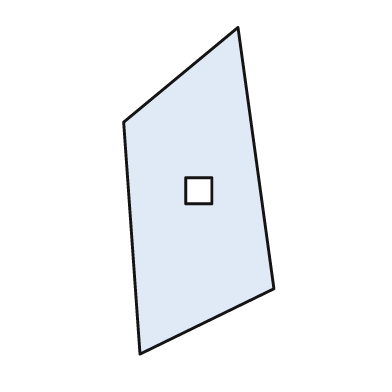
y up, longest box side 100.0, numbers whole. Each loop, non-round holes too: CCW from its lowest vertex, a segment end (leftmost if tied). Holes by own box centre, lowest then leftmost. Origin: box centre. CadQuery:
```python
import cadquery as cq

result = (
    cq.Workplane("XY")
    .moveTo(-18.0, -50.0)
    .lineTo(23.0, -30.0)
    .lineTo(12.0, 50.0)
    .lineTo(-23.0, 21.0)
    .close()
    .moveTo(-4.0, -4.0)
    .lineTo(4.0, -4.0)
    .lineTo(4.0, 4.0)
    .lineTo(-4.0, 4.0)
    .close()
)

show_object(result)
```